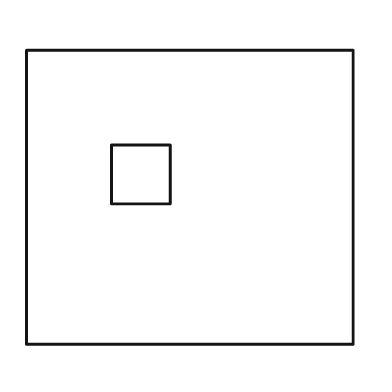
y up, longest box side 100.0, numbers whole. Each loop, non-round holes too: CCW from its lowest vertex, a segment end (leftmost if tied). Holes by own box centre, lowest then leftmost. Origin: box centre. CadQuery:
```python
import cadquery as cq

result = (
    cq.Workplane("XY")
    .moveTo(-50.0, -45.0)
    .lineTo(50.0, -45.0)
    .lineTo(50.0, 45.0)
    .lineTo(-50.0, 45.0)
    .close()
    .moveTo(-24.0, -2.0)
    .lineTo(-6.0, -2.0)
    .lineTo(-6.0, 16.0)
    .lineTo(-24.0, 16.0)
    .close()
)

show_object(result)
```